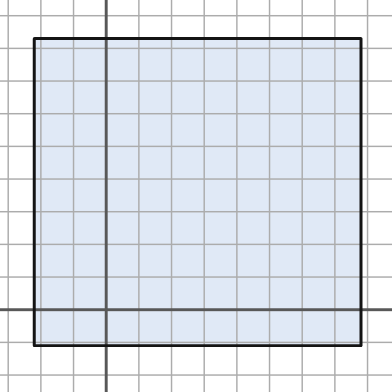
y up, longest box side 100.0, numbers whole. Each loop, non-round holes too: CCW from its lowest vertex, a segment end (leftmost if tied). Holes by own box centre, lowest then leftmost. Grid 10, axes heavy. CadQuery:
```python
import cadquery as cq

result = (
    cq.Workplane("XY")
    .moveTo(-22.0, -11.0)
    .lineTo(78.0, -11.0)
    .lineTo(78.0, 83.0)
    .lineTo(-22.0, 83.0)
    .close()
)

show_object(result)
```